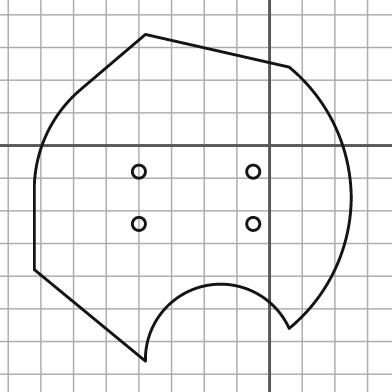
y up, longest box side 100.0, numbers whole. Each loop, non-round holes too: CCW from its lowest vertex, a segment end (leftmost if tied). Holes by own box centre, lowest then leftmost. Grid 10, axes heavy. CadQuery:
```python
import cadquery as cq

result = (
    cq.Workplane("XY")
    .moveTo(-38.0, -66.0)
    .threePointArc((-20.0, -43.0), (6.0, -56.0))
    .threePointArc((20.0, -38.0), (25.0, -16.0))
    .threePointArc((20.0, 6.0), (6.0, 24.0))
    .lineTo(-38.0, 34.0)
    .lineTo(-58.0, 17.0)
    .threePointArc((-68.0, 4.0), (-72.0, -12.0))
    .lineTo(-72.0, -38.0)
    .close()
    .moveTo(-40.0, -24.0)
    .circle(2.0)
    .moveTo(-5.0, -24.0)
    .circle(2.0)
    .moveTo(-40.0, -8.0)
    .circle(2.0)
    .moveTo(-5.0, -8.0)
    .circle(2.0)
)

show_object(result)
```